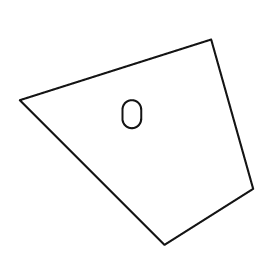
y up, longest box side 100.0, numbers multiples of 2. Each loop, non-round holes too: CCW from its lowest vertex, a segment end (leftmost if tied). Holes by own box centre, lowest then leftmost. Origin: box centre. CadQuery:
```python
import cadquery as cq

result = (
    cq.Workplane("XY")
    .moveTo(12.0, -44.0)
    .lineTo(50.0, -20.0)
    .lineTo(32.0, 44.0)
    .lineTo(-50.0, 18.0)
    .close()
    .moveTo(-6.0, 10.0)
    .threePointArc((-2.0, 6.0), (2.0, 10.0))
    .lineTo(2.0, 14.0)
    .threePointArc((-2.0, 18.0), (-6.0, 14.0))
    .close()
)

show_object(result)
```